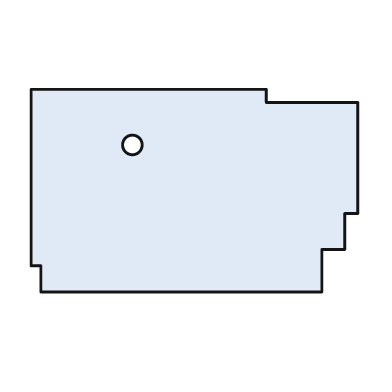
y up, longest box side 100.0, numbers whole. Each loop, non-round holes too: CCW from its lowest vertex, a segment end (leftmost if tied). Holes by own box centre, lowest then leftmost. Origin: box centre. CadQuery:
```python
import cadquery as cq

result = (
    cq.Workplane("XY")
    .moveTo(-47.0, -31.0)
    .lineTo(39.0, -31.0)
    .lineTo(39.0, -18.0)
    .lineTo(46.0, -18.0)
    .lineTo(46.0, -7.0)
    .lineTo(50.0, -7.0)
    .lineTo(50.0, 27.0)
    .lineTo(22.0, 27.0)
    .lineTo(22.0, 31.0)
    .lineTo(-50.0, 31.0)
    .lineTo(-50.0, -23.0)
    .lineTo(-47.0, -23.0)
    .close()
    .moveTo(-19.0, 14.0)
    .circle(3.0)
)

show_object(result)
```